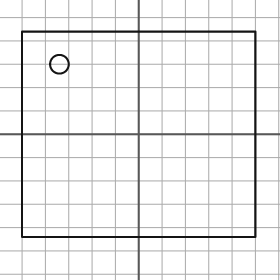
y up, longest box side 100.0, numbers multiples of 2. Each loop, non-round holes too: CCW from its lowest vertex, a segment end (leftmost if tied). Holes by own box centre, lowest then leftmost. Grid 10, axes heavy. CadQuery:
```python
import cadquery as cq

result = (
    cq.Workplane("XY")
    .moveTo(-50.0, -44.0)
    .lineTo(50.0, -44.0)
    .lineTo(50.0, 44.0)
    .lineTo(-50.0, 44.0)
    .close()
    .moveTo(-34.0, 30.0)
    .circle(4.0)
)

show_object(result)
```